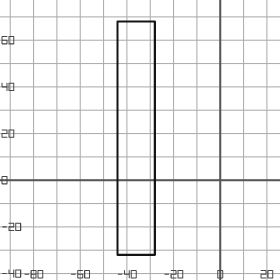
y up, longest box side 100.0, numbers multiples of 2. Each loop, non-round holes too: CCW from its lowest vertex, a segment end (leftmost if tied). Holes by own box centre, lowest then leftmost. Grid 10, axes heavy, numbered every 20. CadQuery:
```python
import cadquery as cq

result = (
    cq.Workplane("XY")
    .moveTo(-44.0, -32.0)
    .lineTo(-28.0, -32.0)
    .lineTo(-28.0, 68.0)
    .lineTo(-44.0, 68.0)
    .close()
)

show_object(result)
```